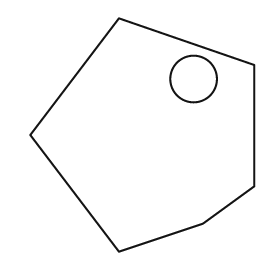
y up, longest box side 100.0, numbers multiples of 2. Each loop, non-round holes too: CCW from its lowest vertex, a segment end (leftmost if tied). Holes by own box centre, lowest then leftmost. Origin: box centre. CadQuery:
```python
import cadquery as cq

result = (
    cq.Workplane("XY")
    .moveTo(-10.0, -50.0)
    .lineTo(26.0, -38.0)
    .lineTo(48.0, -22.0)
    .lineTo(48.0, 30.0)
    .lineTo(-10.0, 50.0)
    .lineTo(-48.0, 0.0)
    .close()
    .moveTo(22.0, 24.0)
    .circle(10.0)
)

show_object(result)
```